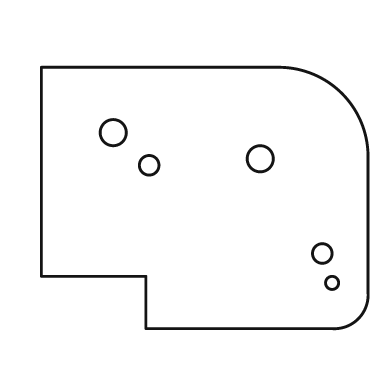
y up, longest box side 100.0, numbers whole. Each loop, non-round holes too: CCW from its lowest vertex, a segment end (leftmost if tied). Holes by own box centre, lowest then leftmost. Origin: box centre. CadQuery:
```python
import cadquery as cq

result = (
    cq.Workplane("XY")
    .moveTo(-18.0, -40.0)
    .lineTo(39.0, -40.0)
    .threePointArc((47.0, -37.0), (50.0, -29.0))
    .lineTo(50.0, 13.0)
    .threePointArc((42.0, 32.0), (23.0, 40.0))
    .lineTo(-50.0, 40.0)
    .lineTo(-50.0, -24.0)
    .lineTo(-18.0, -24.0)
    .close()
    .moveTo(39.0, -26.0)
    .circle(2.0)
    .moveTo(36.0, -17.0)
    .circle(3.0)
    .moveTo(-17.0, 10.0)
    .circle(3.0)
    .moveTo(17.0, 12.0)
    .circle(4.0)
    .moveTo(-28.0, 20.0)
    .circle(4.0)
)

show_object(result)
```